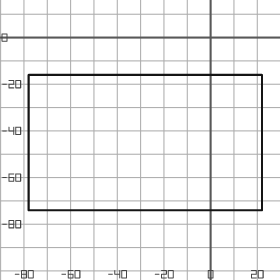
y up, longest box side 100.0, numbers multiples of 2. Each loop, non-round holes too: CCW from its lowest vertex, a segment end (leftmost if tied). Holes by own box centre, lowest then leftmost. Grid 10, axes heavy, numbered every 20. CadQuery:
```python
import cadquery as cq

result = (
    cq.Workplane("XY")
    .moveTo(-78.0, -74.0)
    .lineTo(22.0, -74.0)
    .lineTo(22.0, -16.0)
    .lineTo(-78.0, -16.0)
    .close()
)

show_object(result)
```